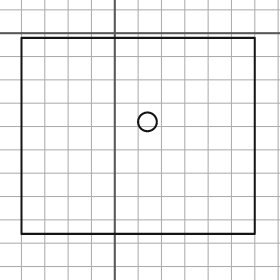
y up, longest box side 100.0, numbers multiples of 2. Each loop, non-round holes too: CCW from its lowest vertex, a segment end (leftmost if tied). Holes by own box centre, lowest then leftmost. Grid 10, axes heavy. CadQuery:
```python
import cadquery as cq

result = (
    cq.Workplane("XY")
    .moveTo(-40.0, -86.0)
    .lineTo(60.0, -86.0)
    .lineTo(60.0, -2.0)
    .lineTo(-40.0, -2.0)
    .close()
    .moveTo(14.0, -38.0)
    .circle(4.0)
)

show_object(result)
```